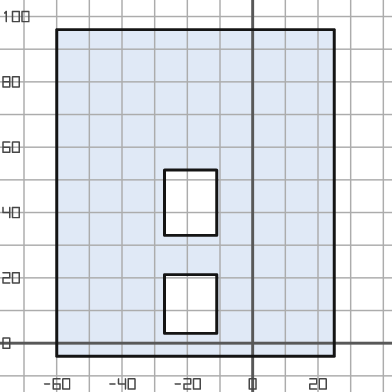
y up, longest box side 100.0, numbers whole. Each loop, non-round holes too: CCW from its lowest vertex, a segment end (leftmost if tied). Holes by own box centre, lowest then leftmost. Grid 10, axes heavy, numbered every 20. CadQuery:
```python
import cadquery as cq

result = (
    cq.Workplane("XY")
    .moveTo(-60.0, -4.0)
    .lineTo(25.0, -4.0)
    .lineTo(25.0, 96.0)
    .lineTo(-60.0, 96.0)
    .close()
    .moveTo(-27.0, 3.0)
    .lineTo(-11.0, 3.0)
    .lineTo(-11.0, 21.0)
    .lineTo(-27.0, 21.0)
    .close()
    .moveTo(-27.0, 33.0)
    .lineTo(-11.0, 33.0)
    .lineTo(-11.0, 53.0)
    .lineTo(-27.0, 53.0)
    .close()
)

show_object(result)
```